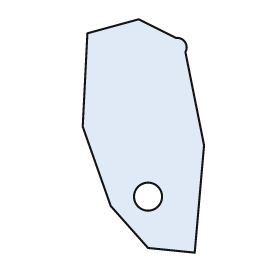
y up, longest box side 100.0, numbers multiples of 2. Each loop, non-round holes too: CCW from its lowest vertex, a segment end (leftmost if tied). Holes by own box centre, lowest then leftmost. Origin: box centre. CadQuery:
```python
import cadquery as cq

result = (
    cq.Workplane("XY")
    .moveTo(22.0, -50.0)
    .lineTo(26.0, -4.0)
    .lineTo(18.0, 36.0)
    .threePointArc((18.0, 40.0), (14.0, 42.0))
    .lineTo(-2.0, 50.0)
    .lineTo(-24.0, 44.0)
    .lineTo(-26.0, 4.0)
    .lineTo(-14.0, -30.0)
    .lineTo(2.0, -48.0)
    .close()
    .moveTo(2.0, -26.0)
    .circle(6.0)
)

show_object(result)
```